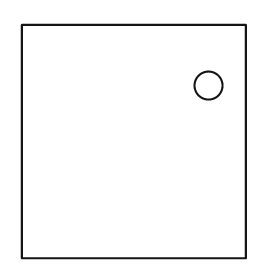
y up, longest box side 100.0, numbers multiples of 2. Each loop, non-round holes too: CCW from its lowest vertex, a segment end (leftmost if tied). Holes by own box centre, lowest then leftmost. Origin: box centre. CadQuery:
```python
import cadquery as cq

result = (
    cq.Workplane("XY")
    .moveTo(-48.0, -50.0)
    .lineTo(48.0, -50.0)
    .lineTo(48.0, 50.0)
    .lineTo(-48.0, 50.0)
    .close()
    .moveTo(32.0, 24.0)
    .circle(6.0)
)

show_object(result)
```